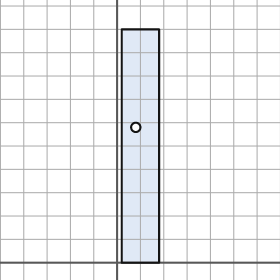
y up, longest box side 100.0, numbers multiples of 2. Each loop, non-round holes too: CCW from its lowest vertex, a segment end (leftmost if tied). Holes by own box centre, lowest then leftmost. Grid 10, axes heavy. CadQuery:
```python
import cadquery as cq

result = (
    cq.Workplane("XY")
    .moveTo(2.0, 0.0)
    .lineTo(18.0, 0.0)
    .lineTo(18.0, 100.0)
    .lineTo(2.0, 100.0)
    .close()
    .moveTo(8.0, 58.0)
    .circle(2.0)
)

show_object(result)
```